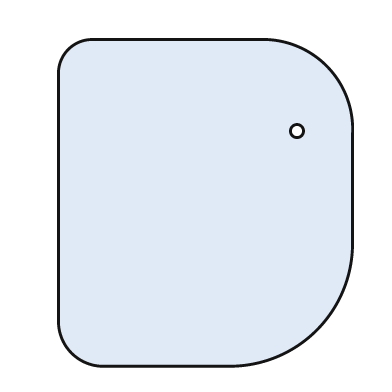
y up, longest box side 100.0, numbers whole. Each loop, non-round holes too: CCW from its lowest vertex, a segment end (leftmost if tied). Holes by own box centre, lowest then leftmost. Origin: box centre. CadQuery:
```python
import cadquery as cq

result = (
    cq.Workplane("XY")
    .moveTo(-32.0, -50.0)
    .lineTo(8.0, -50.0)
    .threePointArc((34.0, -39.0), (45.0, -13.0))
    .lineTo(45.0, 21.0)
    .threePointArc((37.0, 42.0), (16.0, 50.0))
    .lineTo(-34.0, 50.0)
    .threePointArc((-42.0, 47.0), (-45.0, 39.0))
    .lineTo(-45.0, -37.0)
    .threePointArc((-41.0, -46.0), (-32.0, -50.0))
    .close()
    .moveTo(28.0, 22.0)
    .circle(2.0)
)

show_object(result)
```